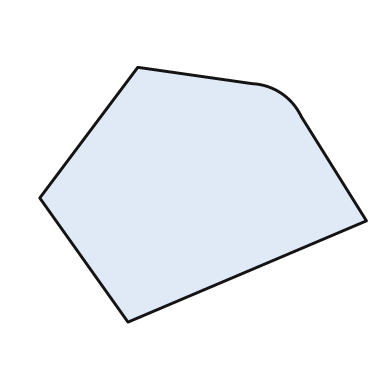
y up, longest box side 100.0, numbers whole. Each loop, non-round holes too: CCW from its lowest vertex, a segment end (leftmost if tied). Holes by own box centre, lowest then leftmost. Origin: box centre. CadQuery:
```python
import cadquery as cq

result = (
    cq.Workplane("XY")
    .moveTo(-23.0, -39.0)
    .lineTo(50.0, -8.0)
    .lineTo(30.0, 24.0)
    .threePointArc((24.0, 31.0), (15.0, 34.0))
    .lineTo(-20.0, 39.0)
    .lineTo(-50.0, -1.0)
    .close()
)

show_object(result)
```